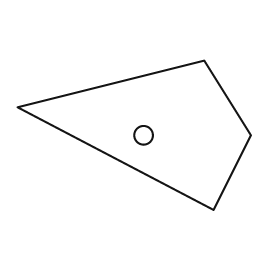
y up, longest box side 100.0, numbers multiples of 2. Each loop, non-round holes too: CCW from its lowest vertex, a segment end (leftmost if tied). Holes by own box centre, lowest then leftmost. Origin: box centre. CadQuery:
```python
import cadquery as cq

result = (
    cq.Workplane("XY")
    .moveTo(34.0, -32.0)
    .lineTo(50.0, 0.0)
    .lineTo(30.0, 32.0)
    .lineTo(-50.0, 12.0)
    .close()
    .moveTo(4.0, 0.0)
    .circle(4.0)
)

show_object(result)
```